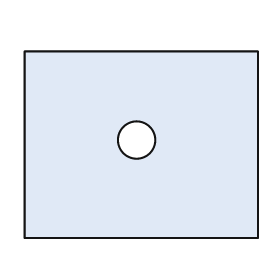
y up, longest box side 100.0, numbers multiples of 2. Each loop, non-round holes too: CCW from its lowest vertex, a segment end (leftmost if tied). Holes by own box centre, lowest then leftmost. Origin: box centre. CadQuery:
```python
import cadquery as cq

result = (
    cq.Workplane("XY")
    .moveTo(-50.0, -40.0)
    .lineTo(50.0, -40.0)
    .lineTo(50.0, 40.0)
    .lineTo(-50.0, 40.0)
    .close()
    .moveTo(-2.0, 2.0)
    .circle(8.0)
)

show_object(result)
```